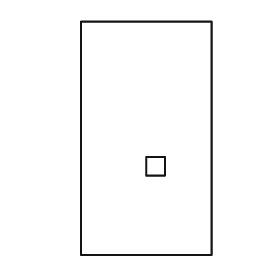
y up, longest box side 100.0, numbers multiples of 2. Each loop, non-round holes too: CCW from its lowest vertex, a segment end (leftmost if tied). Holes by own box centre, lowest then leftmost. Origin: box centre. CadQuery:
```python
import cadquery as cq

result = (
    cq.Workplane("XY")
    .moveTo(-28.0, -50.0)
    .lineTo(28.0, -50.0)
    .lineTo(28.0, 50.0)
    .lineTo(-28.0, 50.0)
    .close()
    .moveTo(0.0, -16.0)
    .lineTo(8.0, -16.0)
    .lineTo(8.0, -8.0)
    .lineTo(0.0, -8.0)
    .close()
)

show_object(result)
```